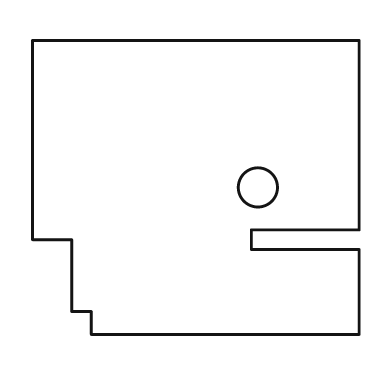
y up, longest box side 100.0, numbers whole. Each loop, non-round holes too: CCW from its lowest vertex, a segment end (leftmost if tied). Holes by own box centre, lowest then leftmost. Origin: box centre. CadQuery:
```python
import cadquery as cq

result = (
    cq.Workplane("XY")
    .moveTo(-32.0, -45.0)
    .lineTo(50.0, -45.0)
    .lineTo(50.0, -19.0)
    .lineTo(17.0, -19.0)
    .lineTo(17.0, -13.0)
    .lineTo(50.0, -13.0)
    .lineTo(50.0, 45.0)
    .lineTo(-50.0, 45.0)
    .lineTo(-50.0, -16.0)
    .lineTo(-38.0, -16.0)
    .lineTo(-38.0, -38.0)
    .lineTo(-32.0, -38.0)
    .close()
    .moveTo(19.0, 0.0)
    .circle(6.0)
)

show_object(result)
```